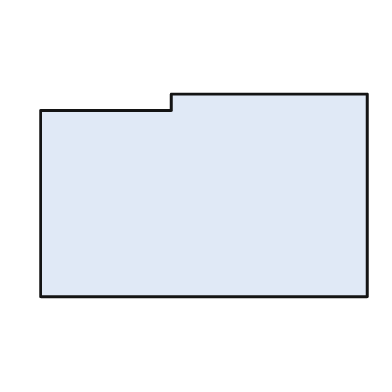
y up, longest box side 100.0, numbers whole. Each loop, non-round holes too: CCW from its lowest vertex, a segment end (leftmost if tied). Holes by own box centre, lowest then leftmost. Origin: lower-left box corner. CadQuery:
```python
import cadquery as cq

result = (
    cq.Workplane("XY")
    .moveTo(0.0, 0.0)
    .lineTo(100.0, 0.0)
    .lineTo(100.0, 62.0)
    .lineTo(40.0, 62.0)
    .lineTo(40.0, 57.0)
    .lineTo(0.0, 57.0)
    .close()
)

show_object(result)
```